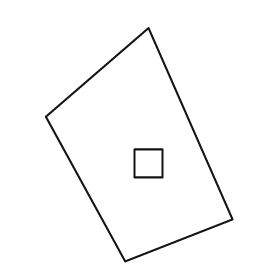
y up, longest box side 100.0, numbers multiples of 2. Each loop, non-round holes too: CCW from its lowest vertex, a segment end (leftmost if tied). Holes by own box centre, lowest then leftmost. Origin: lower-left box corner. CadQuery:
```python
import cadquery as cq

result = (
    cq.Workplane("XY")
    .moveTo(34.0, 0.0)
    .lineTo(80.0, 18.0)
    .lineTo(44.0, 100.0)
    .lineTo(0.0, 62.0)
    .close()
    .moveTo(38.0, 36.0)
    .lineTo(50.0, 36.0)
    .lineTo(50.0, 48.0)
    .lineTo(38.0, 48.0)
    .close()
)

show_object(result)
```